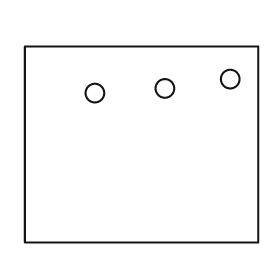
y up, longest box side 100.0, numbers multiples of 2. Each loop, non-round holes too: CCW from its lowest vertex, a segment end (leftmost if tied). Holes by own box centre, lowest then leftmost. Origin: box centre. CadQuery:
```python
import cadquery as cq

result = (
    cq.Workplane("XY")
    .moveTo(-50.0, -42.0)
    .lineTo(50.0, -42.0)
    .lineTo(50.0, 42.0)
    .lineTo(-50.0, 42.0)
    .close()
    .moveTo(-20.0, 22.0)
    .circle(4.0)
    .moveTo(10.0, 24.0)
    .circle(4.0)
    .moveTo(38.0, 28.0)
    .circle(4.0)
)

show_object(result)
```